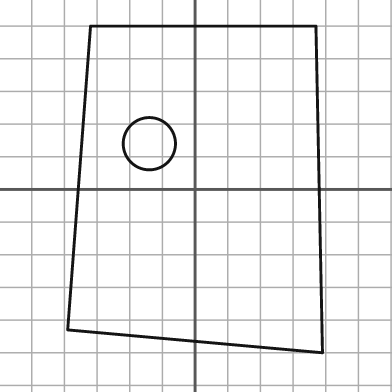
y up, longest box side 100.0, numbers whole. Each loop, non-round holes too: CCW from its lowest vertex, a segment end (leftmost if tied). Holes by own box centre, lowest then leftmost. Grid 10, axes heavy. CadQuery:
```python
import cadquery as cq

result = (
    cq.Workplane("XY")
    .moveTo(39.0, -50.0)
    .lineTo(37.0, 50.0)
    .lineTo(-32.0, 50.0)
    .lineTo(-39.0, -43.0)
    .close()
    .moveTo(-14.0, 14.0)
    .circle(8.0)
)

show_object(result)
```